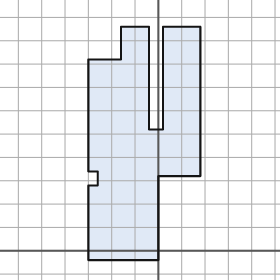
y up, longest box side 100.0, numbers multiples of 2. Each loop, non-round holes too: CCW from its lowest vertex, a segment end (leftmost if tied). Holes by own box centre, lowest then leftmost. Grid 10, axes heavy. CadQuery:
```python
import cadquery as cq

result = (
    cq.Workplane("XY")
    .moveTo(-30.0, -4.0)
    .lineTo(0.0, -4.0)
    .lineTo(0.0, 32.0)
    .lineTo(18.0, 32.0)
    .lineTo(18.0, 96.0)
    .lineTo(2.0, 96.0)
    .lineTo(2.0, 52.0)
    .lineTo(-4.0, 52.0)
    .lineTo(-4.0, 96.0)
    .lineTo(-16.0, 96.0)
    .lineTo(-16.0, 82.0)
    .lineTo(-30.0, 82.0)
    .lineTo(-30.0, 34.0)
    .lineTo(-26.0, 34.0)
    .lineTo(-26.0, 28.0)
    .lineTo(-30.0, 28.0)
    .close()
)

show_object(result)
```